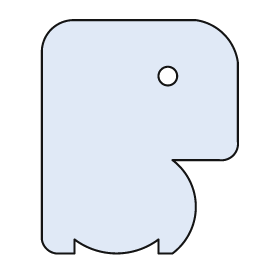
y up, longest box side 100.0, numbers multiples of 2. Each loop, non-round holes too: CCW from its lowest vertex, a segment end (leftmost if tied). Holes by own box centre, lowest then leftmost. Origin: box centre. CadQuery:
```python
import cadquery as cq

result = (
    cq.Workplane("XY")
    .moveTo(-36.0, -50.0)
    .lineTo(-28.0, -50.0)
    .lineTo(-28.0, -44.0)
    .threePointArc((-10.0, -50.0), (8.0, -44.0))
    .lineTo(8.0, -50.0)
    .lineTo(14.0, -50.0)
    .threePointArc((24.0, -30.0), (14.0, -10.0))
    .lineTo(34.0, -10.0)
    .threePointArc((40.0, -8.0), (42.0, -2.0))
    .lineTo(42.0, 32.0)
    .threePointArc((36.0, 44.0), (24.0, 50.0))
    .lineTo(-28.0, 50.0)
    .threePointArc((-38.0, 46.0), (-42.0, 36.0))
    .lineTo(-42.0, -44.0)
    .threePointArc((-40.0, -48.0), (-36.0, -50.0))
    .close()
    .moveTo(12.0, 26.0)
    .circle(4.0)
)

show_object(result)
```